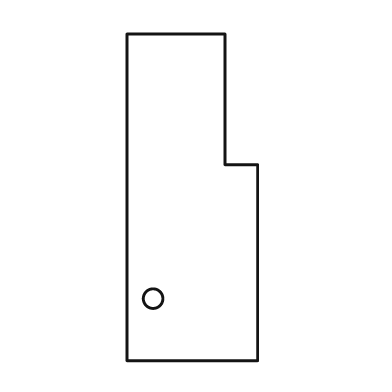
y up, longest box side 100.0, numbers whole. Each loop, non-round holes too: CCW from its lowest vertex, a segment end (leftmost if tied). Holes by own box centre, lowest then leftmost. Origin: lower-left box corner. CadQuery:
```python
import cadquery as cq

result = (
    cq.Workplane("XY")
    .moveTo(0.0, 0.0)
    .lineTo(40.0, 0.0)
    .lineTo(40.0, 60.0)
    .lineTo(30.0, 60.0)
    .lineTo(30.0, 100.0)
    .lineTo(0.0, 100.0)
    .close()
    .moveTo(8.0, 19.0)
    .circle(3.0)
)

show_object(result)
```